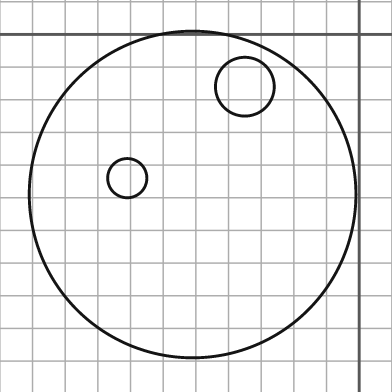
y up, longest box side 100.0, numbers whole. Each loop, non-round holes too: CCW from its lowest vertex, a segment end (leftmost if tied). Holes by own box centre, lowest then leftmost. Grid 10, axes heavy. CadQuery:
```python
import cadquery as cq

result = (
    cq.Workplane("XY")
    .moveTo(-51.0, -49.0)
    .circle(50.0)
    .moveTo(-71.0, -44.0)
    .circle(6.0)
    .moveTo(-35.0, -16.0)
    .circle(9.0)
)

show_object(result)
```